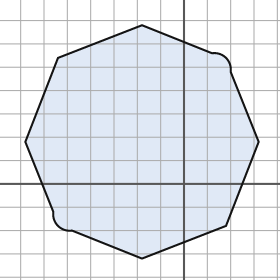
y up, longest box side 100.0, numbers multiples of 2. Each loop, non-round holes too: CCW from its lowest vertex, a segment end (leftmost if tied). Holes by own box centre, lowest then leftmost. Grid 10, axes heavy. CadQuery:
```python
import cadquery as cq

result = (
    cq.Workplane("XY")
    .moveTo(-18.0, -32.0)
    .lineTo(18.0, -18.0)
    .lineTo(32.0, 18.0)
    .lineTo(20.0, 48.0)
    .threePointArc((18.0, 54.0), (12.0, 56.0))
    .lineTo(-18.0, 68.0)
    .lineTo(-54.0, 54.0)
    .lineTo(-68.0, 18.0)
    .lineTo(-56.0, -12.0)
    .threePointArc((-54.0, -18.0), (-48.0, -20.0))
    .close()
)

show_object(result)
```